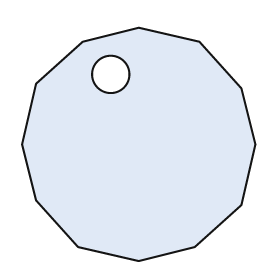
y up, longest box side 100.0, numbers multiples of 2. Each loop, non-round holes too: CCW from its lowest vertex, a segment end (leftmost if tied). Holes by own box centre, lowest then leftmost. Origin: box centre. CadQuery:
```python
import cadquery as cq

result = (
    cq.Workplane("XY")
    .moveTo(0.0, -50.0)
    .lineTo(24.0, -44.0)
    .lineTo(44.0, -26.0)
    .lineTo(50.0, 0.0)
    .lineTo(44.0, 24.0)
    .lineTo(26.0, 44.0)
    .lineTo(0.0, 50.0)
    .lineTo(-24.0, 44.0)
    .lineTo(-44.0, 26.0)
    .lineTo(-50.0, 0.0)
    .lineTo(-44.0, -24.0)
    .lineTo(-26.0, -44.0)
    .close()
    .moveTo(-12.0, 30.0)
    .circle(8.0)
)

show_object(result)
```